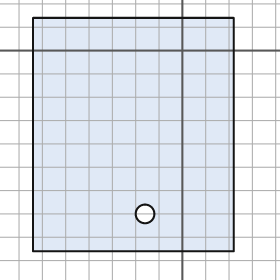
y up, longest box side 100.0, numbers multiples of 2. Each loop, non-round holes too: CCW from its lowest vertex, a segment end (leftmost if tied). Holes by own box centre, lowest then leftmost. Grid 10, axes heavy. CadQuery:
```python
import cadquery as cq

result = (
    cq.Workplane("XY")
    .moveTo(-64.0, -86.0)
    .lineTo(22.0, -86.0)
    .lineTo(22.0, 14.0)
    .lineTo(-64.0, 14.0)
    .close()
    .moveTo(-16.0, -70.0)
    .circle(4.0)
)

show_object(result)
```